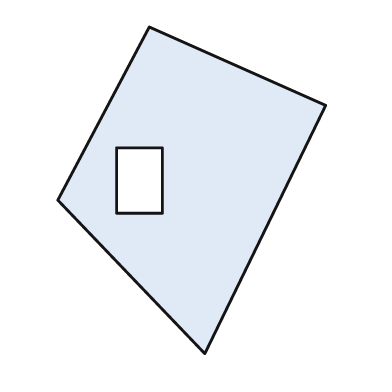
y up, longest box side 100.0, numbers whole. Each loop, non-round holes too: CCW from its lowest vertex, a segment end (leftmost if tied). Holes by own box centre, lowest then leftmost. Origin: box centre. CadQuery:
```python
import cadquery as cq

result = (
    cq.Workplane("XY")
    .moveTo(4.0, -50.0)
    .lineTo(41.0, 26.0)
    .lineTo(-13.0, 50.0)
    .lineTo(-41.0, -3.0)
    .close()
    .moveTo(-23.0, -7.0)
    .lineTo(-9.0, -7.0)
    .lineTo(-9.0, 13.0)
    .lineTo(-23.0, 13.0)
    .close()
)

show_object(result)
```